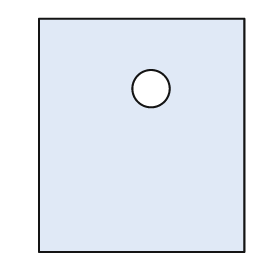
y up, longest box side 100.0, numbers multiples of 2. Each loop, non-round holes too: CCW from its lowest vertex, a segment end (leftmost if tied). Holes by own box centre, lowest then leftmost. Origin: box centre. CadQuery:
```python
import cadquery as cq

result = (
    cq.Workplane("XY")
    .moveTo(-44.0, -50.0)
    .lineTo(44.0, -50.0)
    .lineTo(44.0, 50.0)
    .lineTo(-44.0, 50.0)
    .close()
    .moveTo(4.0, 20.0)
    .circle(8.0)
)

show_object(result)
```